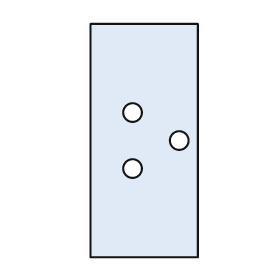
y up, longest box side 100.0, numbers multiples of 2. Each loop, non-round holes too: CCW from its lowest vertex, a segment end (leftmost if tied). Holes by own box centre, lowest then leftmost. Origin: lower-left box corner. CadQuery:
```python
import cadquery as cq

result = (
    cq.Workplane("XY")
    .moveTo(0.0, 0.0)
    .lineTo(46.0, 0.0)
    .lineTo(46.0, 100.0)
    .lineTo(0.0, 100.0)
    .close()
    .moveTo(18.0, 38.0)
    .circle(4.0)
    .moveTo(38.0, 50.0)
    .circle(4.0)
    .moveTo(18.0, 62.0)
    .circle(4.0)
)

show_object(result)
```